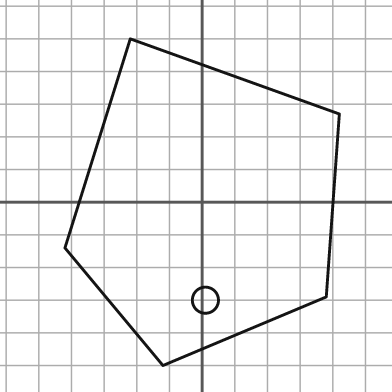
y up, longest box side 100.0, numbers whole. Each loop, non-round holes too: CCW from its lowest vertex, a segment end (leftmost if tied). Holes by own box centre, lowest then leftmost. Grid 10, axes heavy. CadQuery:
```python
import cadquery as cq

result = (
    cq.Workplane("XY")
    .moveTo(-12.0, -50.0)
    .lineTo(38.0, -29.0)
    .lineTo(42.0, 27.0)
    .lineTo(-22.0, 50.0)
    .lineTo(-42.0, -14.0)
    .close()
    .moveTo(1.0, -30.0)
    .circle(4.0)
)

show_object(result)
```